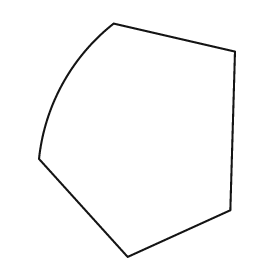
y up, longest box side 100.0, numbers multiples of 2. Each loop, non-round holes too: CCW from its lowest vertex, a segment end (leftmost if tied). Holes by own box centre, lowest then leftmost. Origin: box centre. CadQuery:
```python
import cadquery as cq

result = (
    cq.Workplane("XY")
    .moveTo(-4.0, -50.0)
    .lineTo(40.0, -30.0)
    .lineTo(42.0, 38.0)
    .lineTo(-10.0, 50.0)
    .threePointArc((-32.0, 24.0), (-42.0, -8.0))
    .close()
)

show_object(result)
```